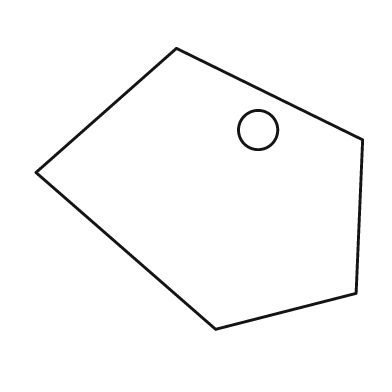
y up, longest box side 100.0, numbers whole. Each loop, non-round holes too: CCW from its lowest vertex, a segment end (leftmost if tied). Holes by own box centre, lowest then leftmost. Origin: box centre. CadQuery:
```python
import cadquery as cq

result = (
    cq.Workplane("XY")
    .moveTo(5.0, -43.0)
    .lineTo(48.0, -32.0)
    .lineTo(50.0, 15.0)
    .lineTo(-7.0, 43.0)
    .lineTo(-50.0, 5.0)
    .close()
    .moveTo(18.0, 18.0)
    .circle(6.0)
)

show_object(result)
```